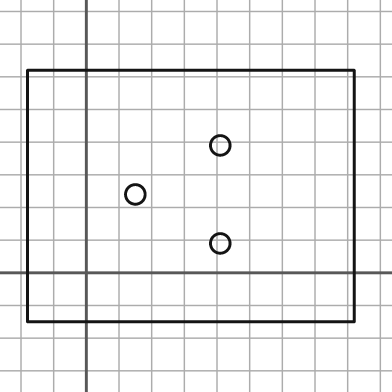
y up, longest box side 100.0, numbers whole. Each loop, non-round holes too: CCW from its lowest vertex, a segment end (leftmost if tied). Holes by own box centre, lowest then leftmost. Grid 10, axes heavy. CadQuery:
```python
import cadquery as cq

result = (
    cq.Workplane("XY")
    .moveTo(-18.0, -15.0)
    .lineTo(82.0, -15.0)
    .lineTo(82.0, 62.0)
    .lineTo(-18.0, 62.0)
    .close()
    .moveTo(41.0, 9.0)
    .circle(3.0)
    .moveTo(15.0, 24.0)
    .circle(3.0)
    .moveTo(41.0, 39.0)
    .circle(3.0)
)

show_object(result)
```